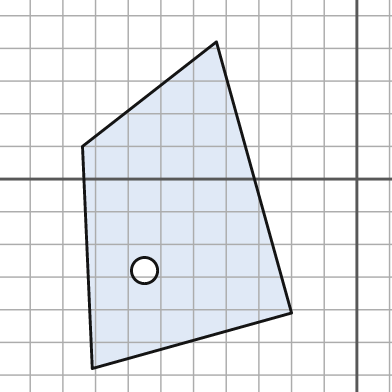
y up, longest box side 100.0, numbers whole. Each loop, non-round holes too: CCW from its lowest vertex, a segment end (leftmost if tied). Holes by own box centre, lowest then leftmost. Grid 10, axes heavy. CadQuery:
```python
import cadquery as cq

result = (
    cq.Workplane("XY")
    .moveTo(-81.0, -58.0)
    .lineTo(-20.0, -41.0)
    .lineTo(-43.0, 42.0)
    .lineTo(-84.0, 10.0)
    .close()
    .moveTo(-65.0, -28.0)
    .circle(4.0)
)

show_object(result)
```